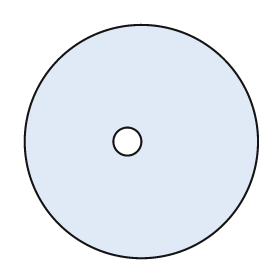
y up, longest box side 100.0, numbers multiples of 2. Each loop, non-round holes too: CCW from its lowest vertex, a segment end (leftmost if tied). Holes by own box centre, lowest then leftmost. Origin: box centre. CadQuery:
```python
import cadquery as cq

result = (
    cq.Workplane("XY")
    .moveTo(0.0, 0.0)
    .circle(50.0)
    .moveTo(-6.0, 0.0)
    .circle(6.0)
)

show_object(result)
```